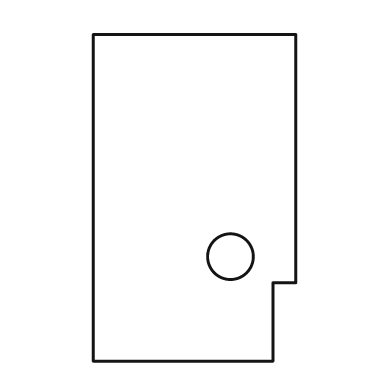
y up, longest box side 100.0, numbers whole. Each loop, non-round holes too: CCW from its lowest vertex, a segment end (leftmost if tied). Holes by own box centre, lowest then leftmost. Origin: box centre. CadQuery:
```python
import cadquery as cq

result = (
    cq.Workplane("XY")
    .moveTo(-31.0, -50.0)
    .lineTo(24.0, -50.0)
    .lineTo(24.0, -26.0)
    .lineTo(31.0, -26.0)
    .lineTo(31.0, 50.0)
    .lineTo(-31.0, 50.0)
    .close()
    .moveTo(11.0, -18.0)
    .circle(7.0)
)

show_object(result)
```